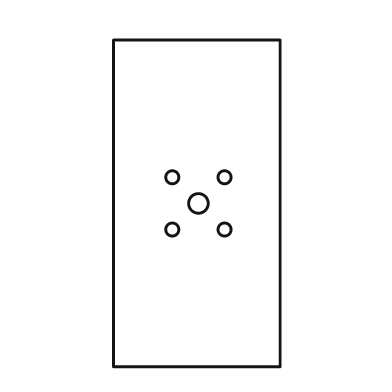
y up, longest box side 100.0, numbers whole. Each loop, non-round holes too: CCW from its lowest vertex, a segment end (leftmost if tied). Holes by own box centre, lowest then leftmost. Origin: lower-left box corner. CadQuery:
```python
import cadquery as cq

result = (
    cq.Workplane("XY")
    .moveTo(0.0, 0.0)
    .lineTo(51.0, 0.0)
    .lineTo(51.0, 100.0)
    .lineTo(0.0, 100.0)
    .close()
    .moveTo(18.0, 42.0)
    .circle(2.0)
    .moveTo(34.0, 42.0)
    .circle(2.0)
    .moveTo(26.0, 50.0)
    .circle(3.0)
    .moveTo(18.0, 58.0)
    .circle(2.0)
    .moveTo(34.0, 58.0)
    .circle(2.0)
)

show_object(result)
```